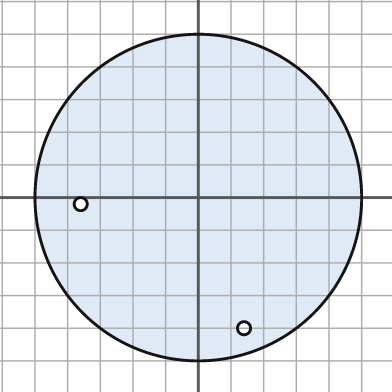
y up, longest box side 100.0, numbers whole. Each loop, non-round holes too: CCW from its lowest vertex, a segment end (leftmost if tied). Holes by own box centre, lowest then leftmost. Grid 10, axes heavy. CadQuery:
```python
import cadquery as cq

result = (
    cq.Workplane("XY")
    .moveTo(0.0, 0.0)
    .circle(50.0)
    .moveTo(14.0, -40.0)
    .circle(2.0)
    .moveTo(-36.0, -2.0)
    .circle(2.0)
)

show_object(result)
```